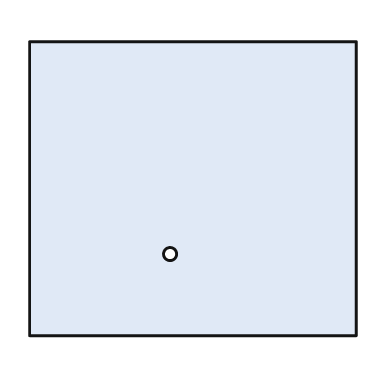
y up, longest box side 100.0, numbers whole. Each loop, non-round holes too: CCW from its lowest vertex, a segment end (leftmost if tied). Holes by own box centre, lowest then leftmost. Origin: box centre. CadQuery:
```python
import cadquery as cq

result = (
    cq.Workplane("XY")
    .moveTo(-50.0, -45.0)
    .lineTo(50.0, -45.0)
    .lineTo(50.0, 45.0)
    .lineTo(-50.0, 45.0)
    .close()
    .moveTo(-7.0, -20.0)
    .circle(2.0)
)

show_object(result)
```